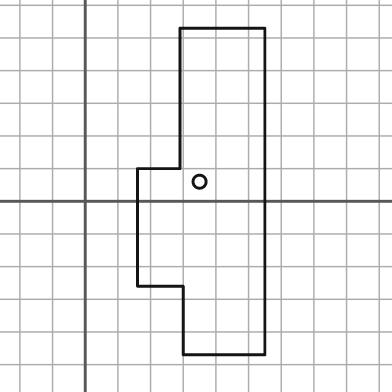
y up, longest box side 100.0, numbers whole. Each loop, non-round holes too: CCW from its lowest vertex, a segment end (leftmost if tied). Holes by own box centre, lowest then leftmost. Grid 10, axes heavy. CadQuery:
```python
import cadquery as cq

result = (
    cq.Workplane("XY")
    .moveTo(30.0, -47.0)
    .lineTo(55.0, -47.0)
    .lineTo(55.0, 53.0)
    .lineTo(29.0, 53.0)
    .lineTo(29.0, 10.0)
    .lineTo(16.0, 10.0)
    .lineTo(16.0, -26.0)
    .lineTo(30.0, -26.0)
    .close()
    .moveTo(35.0, 6.0)
    .circle(2.0)
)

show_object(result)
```